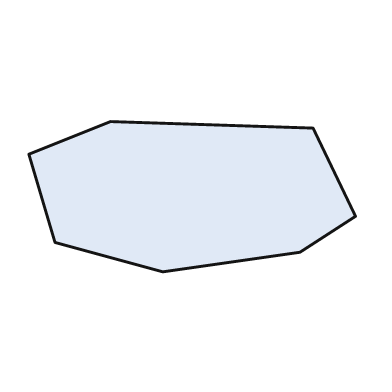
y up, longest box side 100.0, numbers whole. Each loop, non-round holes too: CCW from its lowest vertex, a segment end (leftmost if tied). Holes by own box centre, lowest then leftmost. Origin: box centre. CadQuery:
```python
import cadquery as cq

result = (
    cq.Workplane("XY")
    .moveTo(-9.0, -23.0)
    .lineTo(33.0, -17.0)
    .lineTo(50.0, -6.0)
    .lineTo(37.0, 21.0)
    .lineTo(-25.0, 23.0)
    .lineTo(-50.0, 13.0)
    .lineTo(-42.0, -14.0)
    .close()
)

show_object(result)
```